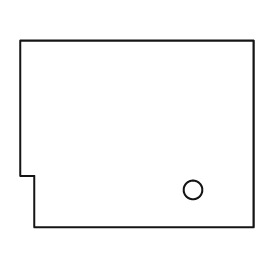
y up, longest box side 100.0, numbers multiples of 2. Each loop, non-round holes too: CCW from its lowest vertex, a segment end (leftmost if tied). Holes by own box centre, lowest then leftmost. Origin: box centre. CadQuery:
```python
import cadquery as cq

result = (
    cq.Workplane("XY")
    .moveTo(-44.0, -40.0)
    .lineTo(50.0, -40.0)
    .lineTo(50.0, 40.0)
    .lineTo(-50.0, 40.0)
    .lineTo(-50.0, -18.0)
    .lineTo(-44.0, -18.0)
    .close()
    .moveTo(24.0, -24.0)
    .circle(4.0)
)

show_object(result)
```